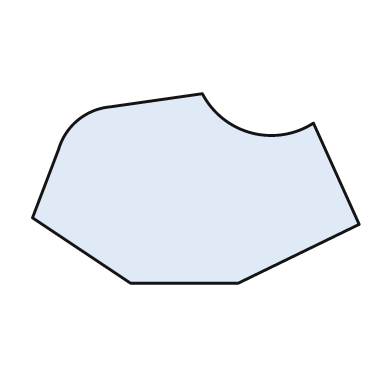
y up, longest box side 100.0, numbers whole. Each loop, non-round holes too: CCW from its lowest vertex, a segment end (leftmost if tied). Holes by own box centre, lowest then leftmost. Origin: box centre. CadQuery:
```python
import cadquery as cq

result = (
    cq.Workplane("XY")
    .moveTo(-20.0, -29.0)
    .lineTo(13.0, -29.0)
    .lineTo(50.0, -11.0)
    .lineTo(36.0, 20.0)
    .threePointArc((17.0, 17.0), (2.0, 29.0))
    .lineTo(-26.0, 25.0)
    .threePointArc((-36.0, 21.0), (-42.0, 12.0))
    .lineTo(-50.0, -9.0)
    .close()
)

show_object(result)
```